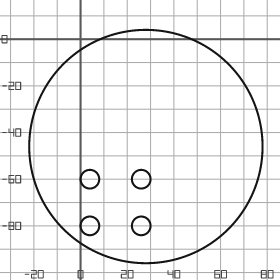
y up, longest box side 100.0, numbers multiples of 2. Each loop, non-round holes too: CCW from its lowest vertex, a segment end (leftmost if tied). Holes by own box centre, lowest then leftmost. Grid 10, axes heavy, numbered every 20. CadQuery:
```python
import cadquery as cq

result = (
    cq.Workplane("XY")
    .moveTo(28.0, -46.0)
    .circle(50.0)
    .moveTo(4.0, -80.0)
    .circle(4.0)
    .moveTo(26.0, -80.0)
    .circle(4.0)
    .moveTo(4.0, -60.0)
    .circle(4.0)
    .moveTo(26.0, -60.0)
    .circle(4.0)
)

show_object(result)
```